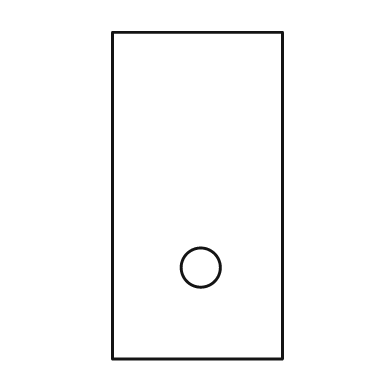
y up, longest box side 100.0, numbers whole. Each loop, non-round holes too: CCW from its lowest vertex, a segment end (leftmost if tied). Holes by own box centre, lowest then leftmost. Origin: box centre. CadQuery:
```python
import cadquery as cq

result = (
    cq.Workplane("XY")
    .moveTo(-26.0, -50.0)
    .lineTo(26.0, -50.0)
    .lineTo(26.0, 50.0)
    .lineTo(-26.0, 50.0)
    .close()
    .moveTo(1.0, -22.0)
    .circle(6.0)
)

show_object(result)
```